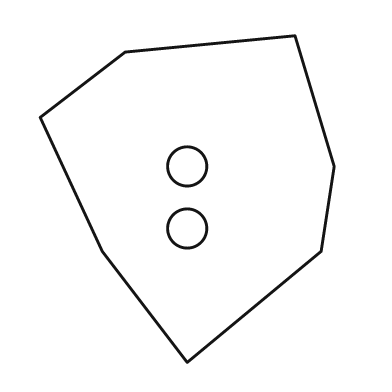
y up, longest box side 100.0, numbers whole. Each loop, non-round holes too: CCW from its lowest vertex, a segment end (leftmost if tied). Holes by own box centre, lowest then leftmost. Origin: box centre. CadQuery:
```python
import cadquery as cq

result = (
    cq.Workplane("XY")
    .moveTo(0.0, -50.0)
    .lineTo(41.0, -16.0)
    .lineTo(45.0, 10.0)
    .lineTo(33.0, 50.0)
    .lineTo(-19.0, 45.0)
    .lineTo(-45.0, 25.0)
    .lineTo(-26.0, -16.0)
    .close()
    .moveTo(0.0, -9.0)
    .circle(6.0)
    .moveTo(0.0, 10.0)
    .circle(6.0)
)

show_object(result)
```